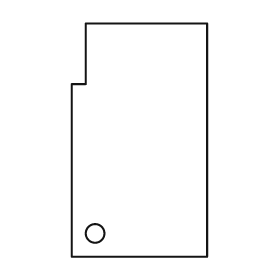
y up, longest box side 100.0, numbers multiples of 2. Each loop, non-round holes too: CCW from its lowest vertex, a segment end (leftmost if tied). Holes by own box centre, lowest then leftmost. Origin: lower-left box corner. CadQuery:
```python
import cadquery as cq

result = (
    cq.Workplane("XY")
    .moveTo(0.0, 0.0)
    .lineTo(58.0, 0.0)
    .lineTo(58.0, 100.0)
    .lineTo(6.0, 100.0)
    .lineTo(6.0, 74.0)
    .lineTo(0.0, 74.0)
    .close()
    .moveTo(10.0, 10.0)
    .circle(4.0)
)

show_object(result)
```